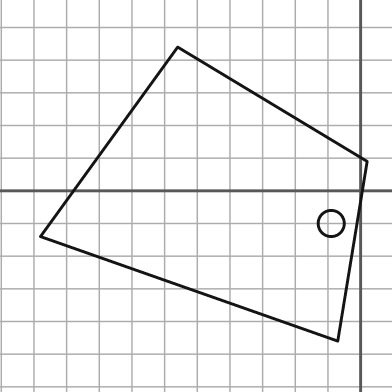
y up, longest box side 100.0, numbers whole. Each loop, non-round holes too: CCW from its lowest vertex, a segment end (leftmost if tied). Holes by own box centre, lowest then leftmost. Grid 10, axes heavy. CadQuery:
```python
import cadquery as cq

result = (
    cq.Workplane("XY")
    .moveTo(-7.0, -46.0)
    .lineTo(2.0, 9.0)
    .lineTo(-56.0, 44.0)
    .lineTo(-98.0, -14.0)
    .close()
    .moveTo(-9.0, -10.0)
    .circle(4.0)
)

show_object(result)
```